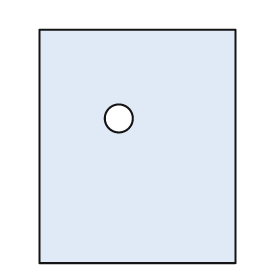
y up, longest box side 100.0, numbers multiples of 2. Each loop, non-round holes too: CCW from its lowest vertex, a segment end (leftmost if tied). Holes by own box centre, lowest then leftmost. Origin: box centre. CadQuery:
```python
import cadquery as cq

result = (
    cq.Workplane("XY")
    .moveTo(-42.0, -50.0)
    .lineTo(42.0, -50.0)
    .lineTo(42.0, 50.0)
    .lineTo(-42.0, 50.0)
    .close()
    .moveTo(-8.0, 12.0)
    .circle(6.0)
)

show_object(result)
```